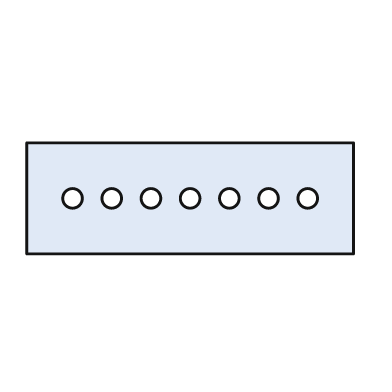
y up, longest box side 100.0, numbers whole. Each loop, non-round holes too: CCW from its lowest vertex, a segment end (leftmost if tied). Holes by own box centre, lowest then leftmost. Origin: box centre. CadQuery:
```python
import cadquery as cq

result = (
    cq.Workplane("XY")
    .moveTo(-50.0, -17.0)
    .lineTo(50.0, -17.0)
    .lineTo(50.0, 17.0)
    .lineTo(-50.0, 17.0)
    .close()
    .moveTo(-36.0, 0.0)
    .circle(3.0)
    .moveTo(-24.0, 0.0)
    .circle(3.0)
    .moveTo(-12.0, 0.0)
    .circle(3.0)
    .moveTo(0.0, 0.0)
    .circle(3.0)
    .moveTo(12.0, 0.0)
    .circle(3.0)
    .moveTo(24.0, 0.0)
    .circle(3.0)
    .moveTo(36.0, 0.0)
    .circle(3.0)
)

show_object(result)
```